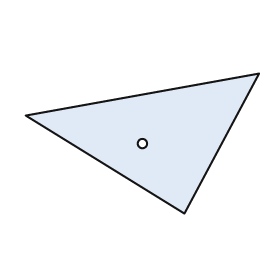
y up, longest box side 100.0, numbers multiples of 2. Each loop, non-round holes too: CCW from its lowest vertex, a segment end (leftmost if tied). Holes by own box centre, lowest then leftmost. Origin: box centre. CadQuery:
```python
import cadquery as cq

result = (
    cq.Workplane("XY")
    .moveTo(18.0, -30.0)
    .lineTo(50.0, 30.0)
    .lineTo(-50.0, 12.0)
    .close()
    .moveTo(0.0, 0.0)
    .circle(2.0)
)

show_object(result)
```